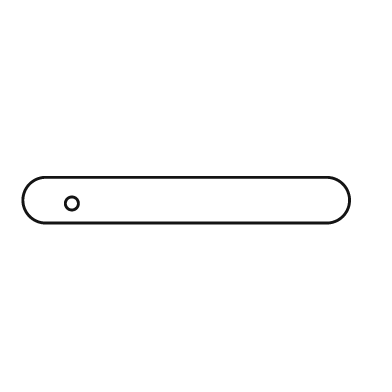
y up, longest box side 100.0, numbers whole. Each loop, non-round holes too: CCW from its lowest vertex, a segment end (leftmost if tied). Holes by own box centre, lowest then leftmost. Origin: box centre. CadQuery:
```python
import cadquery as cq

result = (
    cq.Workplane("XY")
    .moveTo(-43.0, -7.0)
    .lineTo(43.0, -7.0)
    .threePointArc((50.0, 0.0), (43.0, 7.0))
    .lineTo(-43.0, 7.0)
    .threePointArc((-50.0, 0.0), (-43.0, -7.0))
    .close()
    .moveTo(-35.0, -1.0)
    .circle(2.0)
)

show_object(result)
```